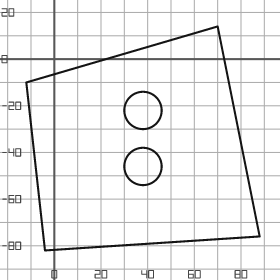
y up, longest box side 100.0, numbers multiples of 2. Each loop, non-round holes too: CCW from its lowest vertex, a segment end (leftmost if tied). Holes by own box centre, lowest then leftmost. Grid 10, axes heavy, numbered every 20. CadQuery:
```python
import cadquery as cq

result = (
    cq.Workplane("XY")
    .moveTo(-4.0, -82.0)
    .lineTo(88.0, -76.0)
    .lineTo(70.0, 14.0)
    .lineTo(-12.0, -10.0)
    .close()
    .moveTo(38.0, -46.0)
    .circle(8.0)
    .moveTo(38.0, -22.0)
    .circle(8.0)
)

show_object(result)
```